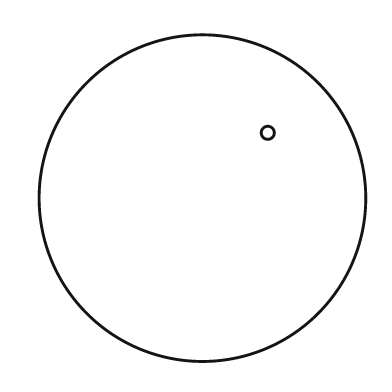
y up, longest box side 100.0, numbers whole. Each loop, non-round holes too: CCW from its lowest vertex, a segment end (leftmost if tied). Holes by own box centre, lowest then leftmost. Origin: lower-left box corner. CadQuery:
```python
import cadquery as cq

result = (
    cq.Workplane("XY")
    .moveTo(50.0, 50.0)
    .circle(50.0)
    .moveTo(70.0, 70.0)
    .circle(2.0)
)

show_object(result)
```